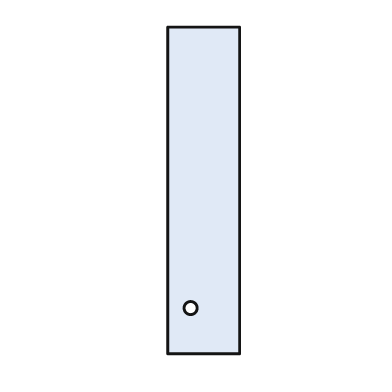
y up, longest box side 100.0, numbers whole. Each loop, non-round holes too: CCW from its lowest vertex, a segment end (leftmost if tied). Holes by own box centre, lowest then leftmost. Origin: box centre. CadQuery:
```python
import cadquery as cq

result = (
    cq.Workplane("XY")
    .moveTo(-11.0, -50.0)
    .lineTo(11.0, -50.0)
    .lineTo(11.0, 50.0)
    .lineTo(-11.0, 50.0)
    .close()
    .moveTo(-4.0, -36.0)
    .circle(2.0)
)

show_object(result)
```